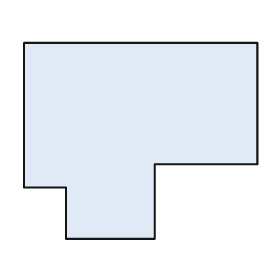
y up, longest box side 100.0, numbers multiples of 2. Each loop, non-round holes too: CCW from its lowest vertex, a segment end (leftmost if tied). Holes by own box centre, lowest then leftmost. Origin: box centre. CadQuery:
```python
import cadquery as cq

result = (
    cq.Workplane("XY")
    .moveTo(-32.0, -42.0)
    .lineTo(6.0, -42.0)
    .lineTo(6.0, -10.0)
    .lineTo(50.0, -10.0)
    .lineTo(50.0, 42.0)
    .lineTo(-50.0, 42.0)
    .lineTo(-50.0, -20.0)
    .lineTo(-32.0, -20.0)
    .close()
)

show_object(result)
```